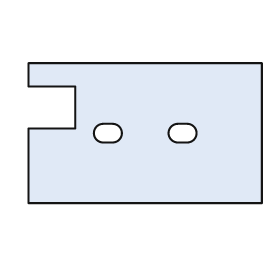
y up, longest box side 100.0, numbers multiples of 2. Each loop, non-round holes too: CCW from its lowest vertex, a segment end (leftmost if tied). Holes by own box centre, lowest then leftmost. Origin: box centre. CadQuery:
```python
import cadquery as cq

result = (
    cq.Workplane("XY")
    .moveTo(-50.0, -30.0)
    .lineTo(50.0, -30.0)
    .lineTo(50.0, 30.0)
    .lineTo(-50.0, 30.0)
    .lineTo(-50.0, 20.0)
    .lineTo(-30.0, 20.0)
    .lineTo(-30.0, 2.0)
    .lineTo(-50.0, 2.0)
    .close()
    .moveTo(-18.0, -4.0)
    .lineTo(-14.0, -4.0)
    .threePointArc((-10.0, 0.0), (-14.0, 4.0))
    .lineTo(-18.0, 4.0)
    .threePointArc((-22.0, 0.0), (-18.0, -4.0))
    .close()
    .moveTo(14.0, -4.0)
    .lineTo(18.0, -4.0)
    .threePointArc((22.0, 0.0), (18.0, 4.0))
    .lineTo(14.0, 4.0)
    .threePointArc((10.0, 0.0), (14.0, -4.0))
    .close()
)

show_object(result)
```